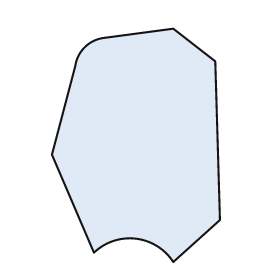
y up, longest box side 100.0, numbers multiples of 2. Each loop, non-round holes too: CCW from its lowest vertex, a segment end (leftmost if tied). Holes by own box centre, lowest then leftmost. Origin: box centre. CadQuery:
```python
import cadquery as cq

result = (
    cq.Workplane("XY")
    .moveTo(16.0, -50.0)
    .lineTo(36.0, -32.0)
    .lineTo(34.0, 36.0)
    .lineTo(16.0, 50.0)
    .lineTo(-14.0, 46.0)
    .threePointArc((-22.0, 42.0), (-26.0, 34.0))
    .lineTo(-36.0, -4.0)
    .lineTo(-18.0, -46.0)
    .threePointArc((0.0, -40.0), (16.0, -50.0))
    .close()
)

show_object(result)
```